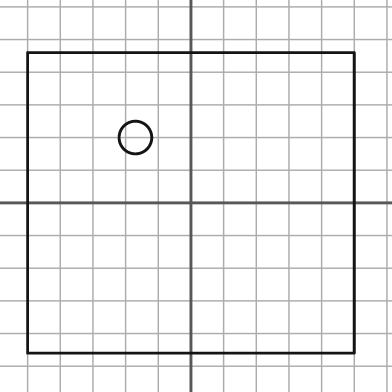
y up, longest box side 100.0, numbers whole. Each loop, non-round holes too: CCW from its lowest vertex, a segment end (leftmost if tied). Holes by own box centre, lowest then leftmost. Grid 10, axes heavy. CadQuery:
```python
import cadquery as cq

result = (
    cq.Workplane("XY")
    .moveTo(-50.0, -46.0)
    .lineTo(50.0, -46.0)
    .lineTo(50.0, 46.0)
    .lineTo(-50.0, 46.0)
    .close()
    .moveTo(-17.0, 20.0)
    .circle(5.0)
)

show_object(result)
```